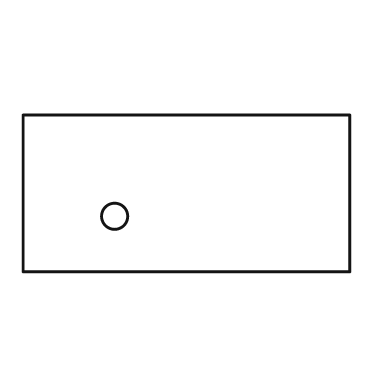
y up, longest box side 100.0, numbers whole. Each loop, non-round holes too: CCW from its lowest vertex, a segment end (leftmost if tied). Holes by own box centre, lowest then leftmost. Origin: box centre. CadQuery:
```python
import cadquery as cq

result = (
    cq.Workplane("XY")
    .moveTo(-50.0, -24.0)
    .lineTo(50.0, -24.0)
    .lineTo(50.0, 24.0)
    .lineTo(-50.0, 24.0)
    .close()
    .moveTo(-22.0, -7.0)
    .circle(4.0)
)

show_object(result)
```